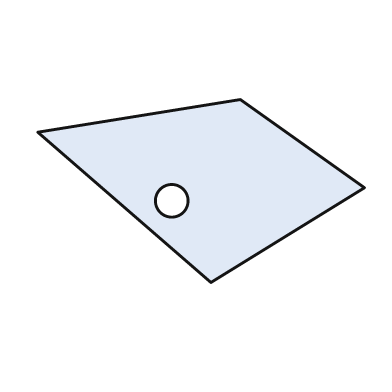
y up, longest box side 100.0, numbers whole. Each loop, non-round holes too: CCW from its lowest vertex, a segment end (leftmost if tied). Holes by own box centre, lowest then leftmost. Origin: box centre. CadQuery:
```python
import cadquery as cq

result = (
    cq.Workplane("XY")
    .moveTo(3.0, -28.0)
    .lineTo(50.0, 1.0)
    .lineTo(12.0, 28.0)
    .lineTo(-50.0, 18.0)
    .close()
    .moveTo(-9.0, -3.0)
    .circle(5.0)
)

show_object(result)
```